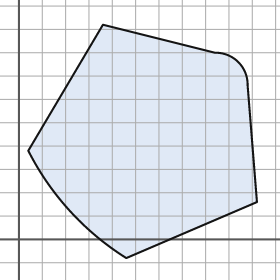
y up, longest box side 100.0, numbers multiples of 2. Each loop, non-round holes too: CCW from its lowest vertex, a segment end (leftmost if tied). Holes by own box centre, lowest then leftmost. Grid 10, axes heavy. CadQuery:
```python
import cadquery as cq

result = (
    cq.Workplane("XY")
    .moveTo(46.0, -8.0)
    .lineTo(102.0, 16.0)
    .lineTo(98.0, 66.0)
    .threePointArc((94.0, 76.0), (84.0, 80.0))
    .lineTo(36.0, 92.0)
    .lineTo(4.0, 38.0)
    .threePointArc((22.0, 12.0), (46.0, -8.0))
    .close()
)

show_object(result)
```